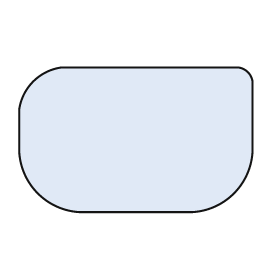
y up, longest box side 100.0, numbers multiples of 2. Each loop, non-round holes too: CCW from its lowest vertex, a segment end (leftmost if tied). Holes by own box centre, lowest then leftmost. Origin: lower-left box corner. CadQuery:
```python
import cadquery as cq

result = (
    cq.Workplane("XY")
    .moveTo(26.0, 0.0)
    .lineTo(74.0, 0.0)
    .threePointArc((92.0, 8.0), (100.0, 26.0))
    .lineTo(100.0, 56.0)
    .threePointArc((98.0, 60.0), (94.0, 62.0))
    .lineTo(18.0, 62.0)
    .threePointArc((6.0, 56.0), (0.0, 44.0))
    .lineTo(0.0, 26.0)
    .threePointArc((8.0, 8.0), (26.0, 0.0))
    .close()
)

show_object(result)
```